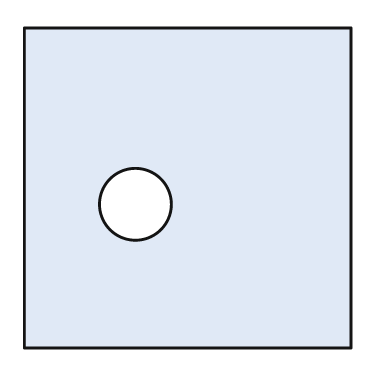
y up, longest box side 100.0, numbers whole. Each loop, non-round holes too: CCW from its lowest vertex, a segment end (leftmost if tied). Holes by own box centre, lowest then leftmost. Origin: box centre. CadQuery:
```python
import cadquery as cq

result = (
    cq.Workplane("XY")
    .moveTo(-50.0, -49.0)
    .lineTo(50.0, -49.0)
    .lineTo(50.0, 49.0)
    .lineTo(-50.0, 49.0)
    .close()
    .moveTo(-16.0, -5.0)
    .circle(11.0)
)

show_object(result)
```